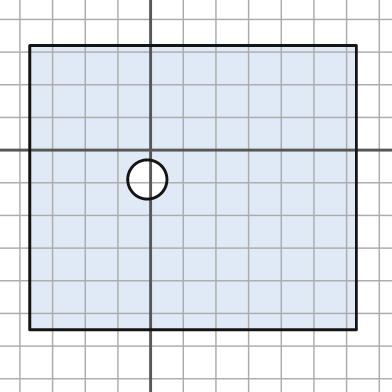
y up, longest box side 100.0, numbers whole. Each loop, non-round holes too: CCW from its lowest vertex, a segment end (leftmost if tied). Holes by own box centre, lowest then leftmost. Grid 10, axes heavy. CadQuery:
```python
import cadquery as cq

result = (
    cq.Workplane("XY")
    .moveTo(-37.0, -55.0)
    .lineTo(63.0, -55.0)
    .lineTo(63.0, 32.0)
    .lineTo(-37.0, 32.0)
    .close()
    .moveTo(-1.0, -9.0)
    .circle(6.0)
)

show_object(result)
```